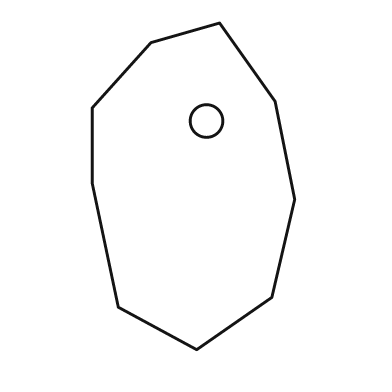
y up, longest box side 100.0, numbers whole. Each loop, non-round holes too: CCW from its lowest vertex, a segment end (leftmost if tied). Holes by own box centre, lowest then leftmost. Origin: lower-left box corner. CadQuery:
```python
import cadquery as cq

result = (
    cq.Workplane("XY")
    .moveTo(32.0, 0.0)
    .lineTo(55.0, 16.0)
    .lineTo(62.0, 46.0)
    .lineTo(56.0, 76.0)
    .lineTo(39.0, 100.0)
    .lineTo(18.0, 94.0)
    .lineTo(0.0, 74.0)
    .lineTo(0.0, 51.0)
    .lineTo(8.0, 13.0)
    .close()
    .moveTo(35.0, 70.0)
    .circle(5.0)
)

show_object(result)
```